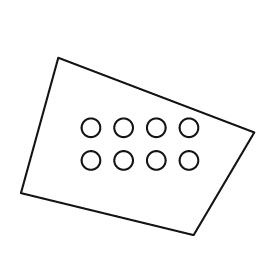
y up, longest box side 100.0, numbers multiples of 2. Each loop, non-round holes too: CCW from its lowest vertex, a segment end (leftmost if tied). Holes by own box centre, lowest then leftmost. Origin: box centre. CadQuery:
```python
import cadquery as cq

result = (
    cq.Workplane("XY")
    .moveTo(24.0, -38.0)
    .lineTo(50.0, 6.0)
    .lineTo(-34.0, 38.0)
    .lineTo(-50.0, -20.0)
    .close()
    .moveTo(-20.0, -6.0)
    .circle(4.0)
    .moveTo(-6.0, -6.0)
    .circle(4.0)
    .moveTo(8.0, -6.0)
    .circle(4.0)
    .moveTo(22.0, -6.0)
    .circle(4.0)
    .moveTo(-20.0, 8.0)
    .circle(4.0)
    .moveTo(-6.0, 8.0)
    .circle(4.0)
    .moveTo(8.0, 8.0)
    .circle(4.0)
    .moveTo(22.0, 8.0)
    .circle(4.0)
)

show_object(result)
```